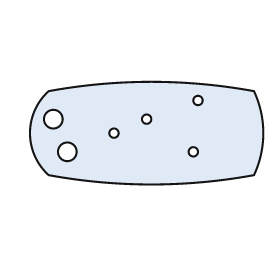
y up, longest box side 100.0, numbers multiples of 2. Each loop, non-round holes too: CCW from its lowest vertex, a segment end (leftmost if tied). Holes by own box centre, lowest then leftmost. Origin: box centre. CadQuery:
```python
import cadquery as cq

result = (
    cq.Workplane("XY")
    .moveTo(-42.0, -18.0)
    .threePointArc((2.0, -22.0), (46.0, -18.0))
    .threePointArc((50.0, 0.0), (46.0, 18.0))
    .threePointArc((2.0, 22.0), (-42.0, 18.0))
    .threePointArc((-50.0, 0.0), (-42.0, -18.0))
    .close()
    .moveTo(-34.0, -8.0)
    .circle(4.0)
    .moveTo(20.0, -8.0)
    .circle(2.0)
    .moveTo(-14.0, 0.0)
    .circle(2.0)
    .moveTo(-40.0, 6.0)
    .circle(4.0)
    .moveTo(0.0, 6.0)
    .circle(2.0)
    .moveTo(22.0, 14.0)
    .circle(2.0)
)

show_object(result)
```